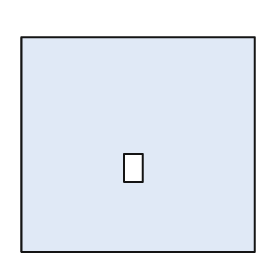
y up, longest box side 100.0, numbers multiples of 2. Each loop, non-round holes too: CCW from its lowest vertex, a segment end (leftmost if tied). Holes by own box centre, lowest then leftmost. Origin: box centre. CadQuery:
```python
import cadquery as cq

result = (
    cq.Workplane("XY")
    .moveTo(-50.0, -46.0)
    .lineTo(50.0, -46.0)
    .lineTo(50.0, 46.0)
    .lineTo(-50.0, 46.0)
    .close()
    .moveTo(-6.0, -16.0)
    .lineTo(2.0, -16.0)
    .lineTo(2.0, -4.0)
    .lineTo(-6.0, -4.0)
    .close()
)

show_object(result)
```